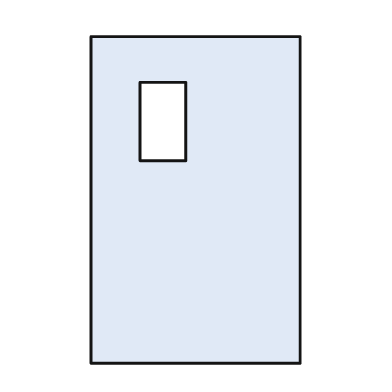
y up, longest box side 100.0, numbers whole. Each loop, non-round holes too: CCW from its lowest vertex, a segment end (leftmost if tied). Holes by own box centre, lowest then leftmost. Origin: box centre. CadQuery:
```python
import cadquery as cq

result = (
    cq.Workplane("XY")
    .moveTo(-32.0, -50.0)
    .lineTo(32.0, -50.0)
    .lineTo(32.0, 50.0)
    .lineTo(-32.0, 50.0)
    .close()
    .moveTo(-17.0, 12.0)
    .lineTo(-3.0, 12.0)
    .lineTo(-3.0, 36.0)
    .lineTo(-17.0, 36.0)
    .close()
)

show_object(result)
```